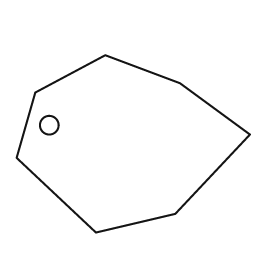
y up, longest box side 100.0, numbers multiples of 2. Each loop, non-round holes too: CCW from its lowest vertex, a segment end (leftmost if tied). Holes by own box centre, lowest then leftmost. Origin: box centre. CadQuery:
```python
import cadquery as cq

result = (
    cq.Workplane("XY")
    .moveTo(-16.0, -38.0)
    .lineTo(18.0, -30.0)
    .lineTo(50.0, 4.0)
    .lineTo(20.0, 26.0)
    .lineTo(-12.0, 38.0)
    .lineTo(-42.0, 22.0)
    .lineTo(-50.0, -6.0)
    .close()
    .moveTo(-36.0, 8.0)
    .circle(4.0)
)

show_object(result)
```